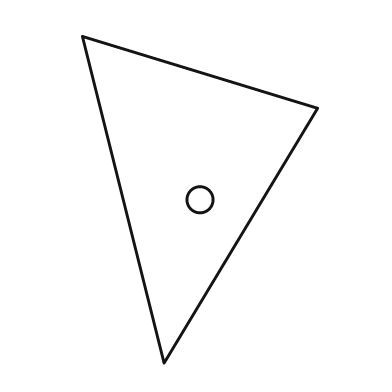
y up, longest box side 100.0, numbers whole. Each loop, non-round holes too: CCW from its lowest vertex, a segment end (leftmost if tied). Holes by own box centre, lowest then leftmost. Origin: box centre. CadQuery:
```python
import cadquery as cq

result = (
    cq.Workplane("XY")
    .moveTo(-11.0, -50.0)
    .lineTo(36.0, 28.0)
    .lineTo(-36.0, 50.0)
    .close()
    .moveTo(0.0, 0.0)
    .circle(4.0)
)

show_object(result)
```